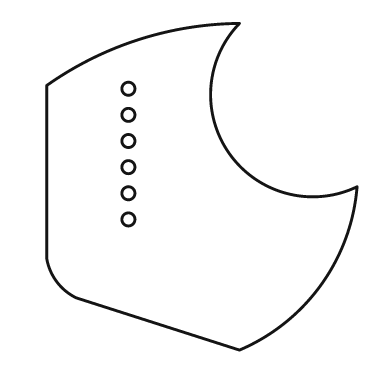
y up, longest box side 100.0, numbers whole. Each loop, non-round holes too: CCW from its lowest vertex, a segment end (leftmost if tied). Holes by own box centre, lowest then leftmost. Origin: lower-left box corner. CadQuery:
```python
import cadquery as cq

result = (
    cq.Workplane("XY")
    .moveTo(59.0, 0.0)
    .threePointArc((84.0, 20.0), (95.0, 50.0))
    .threePointArc((56.0, 60.0), (59.0, 100.0))
    .threePointArc((28.0, 95.0), (0.0, 81.0))
    .lineTo(0.0, 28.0)
    .threePointArc((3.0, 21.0), (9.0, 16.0))
    .close()
    .moveTo(25.0, 40.0)
    .circle(2.0)
    .moveTo(25.0, 48.0)
    .circle(2.0)
    .moveTo(25.0, 56.0)
    .circle(2.0)
    .moveTo(25.0, 64.0)
    .circle(2.0)
    .moveTo(25.0, 72.0)
    .circle(2.0)
    .moveTo(25.0, 80.0)
    .circle(2.0)
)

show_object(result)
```